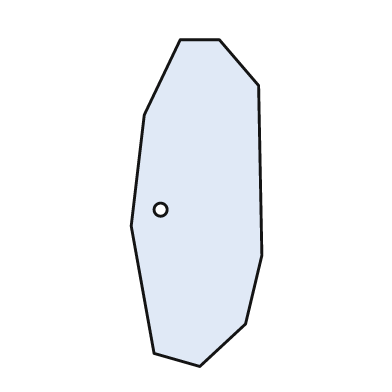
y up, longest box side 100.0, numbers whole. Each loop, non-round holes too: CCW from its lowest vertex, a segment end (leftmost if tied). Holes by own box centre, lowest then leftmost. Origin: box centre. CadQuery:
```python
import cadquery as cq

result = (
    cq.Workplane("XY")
    .moveTo(1.0, -50.0)
    .lineTo(15.0, -37.0)
    .lineTo(20.0, -16.0)
    .lineTo(19.0, 36.0)
    .lineTo(7.0, 50.0)
    .lineTo(-5.0, 50.0)
    .lineTo(-16.0, 27.0)
    .lineTo(-20.0, -7.0)
    .lineTo(-13.0, -46.0)
    .close()
    .moveTo(-11.0, -2.0)
    .circle(2.0)
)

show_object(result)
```